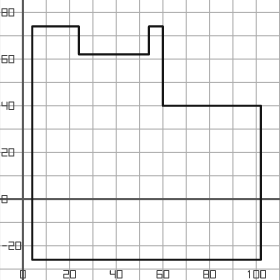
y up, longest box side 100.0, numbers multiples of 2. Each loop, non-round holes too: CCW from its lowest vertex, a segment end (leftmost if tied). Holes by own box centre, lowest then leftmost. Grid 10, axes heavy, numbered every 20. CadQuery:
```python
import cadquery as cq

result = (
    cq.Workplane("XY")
    .moveTo(4.0, -26.0)
    .lineTo(102.0, -26.0)
    .lineTo(102.0, 40.0)
    .lineTo(60.0, 40.0)
    .lineTo(60.0, 74.0)
    .lineTo(54.0, 74.0)
    .lineTo(54.0, 62.0)
    .lineTo(24.0, 62.0)
    .lineTo(24.0, 74.0)
    .lineTo(4.0, 74.0)
    .close()
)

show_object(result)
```